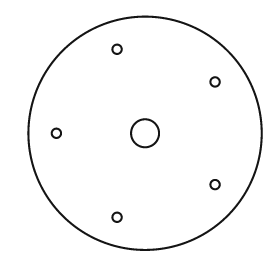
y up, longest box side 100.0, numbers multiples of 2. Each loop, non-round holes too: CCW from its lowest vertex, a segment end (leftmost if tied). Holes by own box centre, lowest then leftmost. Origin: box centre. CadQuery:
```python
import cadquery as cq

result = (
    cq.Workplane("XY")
    .moveTo(0.0, 0.0)
    .circle(50.0)
    .moveTo(-12.0, -36.0)
    .circle(2.0)
    .moveTo(30.0, -22.0)
    .circle(2.0)
    .moveTo(-38.0, 0.0)
    .circle(2.0)
    .moveTo(0.0, 0.0)
    .circle(6.0)
    .moveTo(30.0, 22.0)
    .circle(2.0)
    .moveTo(-12.0, 36.0)
    .circle(2.0)
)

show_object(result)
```